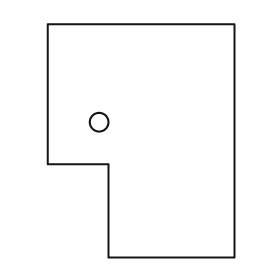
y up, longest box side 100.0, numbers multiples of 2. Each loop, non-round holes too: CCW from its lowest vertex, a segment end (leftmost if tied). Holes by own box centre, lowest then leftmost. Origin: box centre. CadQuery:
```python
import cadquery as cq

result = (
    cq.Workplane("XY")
    .moveTo(-14.0, -50.0)
    .lineTo(40.0, -50.0)
    .lineTo(40.0, 50.0)
    .lineTo(-40.0, 50.0)
    .lineTo(-40.0, -10.0)
    .lineTo(-14.0, -10.0)
    .close()
    .moveTo(-18.0, 8.0)
    .circle(4.0)
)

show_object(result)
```